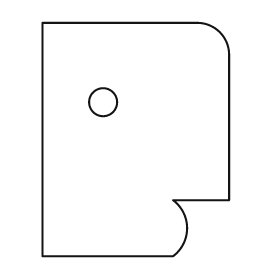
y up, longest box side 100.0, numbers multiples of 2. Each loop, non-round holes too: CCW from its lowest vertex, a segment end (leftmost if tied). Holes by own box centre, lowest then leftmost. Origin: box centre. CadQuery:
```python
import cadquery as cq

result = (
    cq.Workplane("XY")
    .moveTo(-40.0, -50.0)
    .lineTo(16.0, -50.0)
    .threePointArc((22.0, -38.0), (16.0, -26.0))
    .lineTo(40.0, -26.0)
    .lineTo(40.0, 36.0)
    .threePointArc((36.0, 46.0), (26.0, 50.0))
    .lineTo(-40.0, 50.0)
    .close()
    .moveTo(-14.0, 16.0)
    .circle(6.0)
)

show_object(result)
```